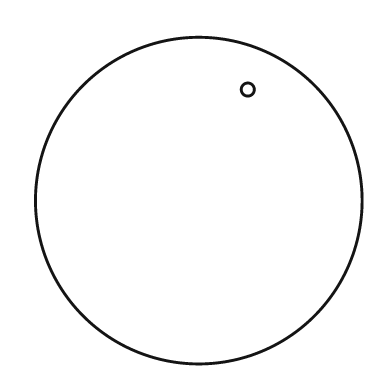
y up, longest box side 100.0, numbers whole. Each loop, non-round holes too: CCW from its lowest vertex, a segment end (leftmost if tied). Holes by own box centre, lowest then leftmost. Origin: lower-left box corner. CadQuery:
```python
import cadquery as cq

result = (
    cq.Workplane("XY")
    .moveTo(50.0, 50.0)
    .circle(50.0)
    .moveTo(65.0, 84.0)
    .circle(2.0)
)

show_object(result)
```